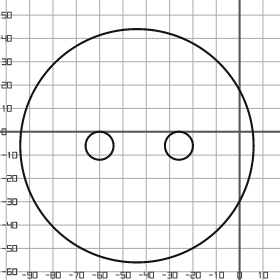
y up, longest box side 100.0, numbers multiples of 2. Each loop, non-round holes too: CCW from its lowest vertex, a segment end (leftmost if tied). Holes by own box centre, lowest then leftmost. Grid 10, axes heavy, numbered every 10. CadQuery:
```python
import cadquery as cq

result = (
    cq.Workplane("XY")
    .moveTo(-44.0, -6.0)
    .circle(50.0)
    .moveTo(-60.0, -6.0)
    .circle(6.0)
    .moveTo(-26.0, -6.0)
    .circle(6.0)
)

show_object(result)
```